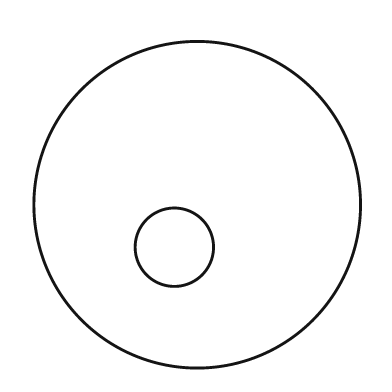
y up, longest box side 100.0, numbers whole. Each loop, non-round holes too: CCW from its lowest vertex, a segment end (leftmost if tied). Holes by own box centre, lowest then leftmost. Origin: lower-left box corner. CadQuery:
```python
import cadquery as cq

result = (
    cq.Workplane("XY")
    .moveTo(50.0, 50.0)
    .circle(50.0)
    .moveTo(43.0, 37.0)
    .circle(12.0)
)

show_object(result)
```